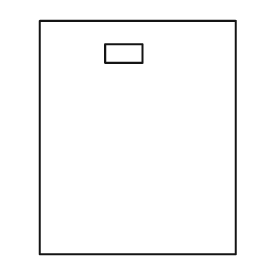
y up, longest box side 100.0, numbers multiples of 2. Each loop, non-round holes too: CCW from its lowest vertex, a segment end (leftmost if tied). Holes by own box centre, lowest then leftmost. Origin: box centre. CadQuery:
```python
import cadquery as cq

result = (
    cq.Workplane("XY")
    .moveTo(-42.0, -50.0)
    .lineTo(42.0, -50.0)
    .lineTo(42.0, 50.0)
    .lineTo(-42.0, 50.0)
    .close()
    .moveTo(-14.0, 32.0)
    .lineTo(2.0, 32.0)
    .lineTo(2.0, 40.0)
    .lineTo(-14.0, 40.0)
    .close()
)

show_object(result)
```